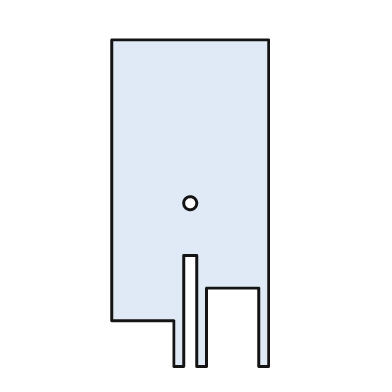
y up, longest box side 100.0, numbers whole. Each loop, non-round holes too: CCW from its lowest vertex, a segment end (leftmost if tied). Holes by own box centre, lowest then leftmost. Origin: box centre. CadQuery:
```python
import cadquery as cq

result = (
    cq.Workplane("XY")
    .moveTo(-5.0, -50.0)
    .lineTo(-2.0, -50.0)
    .lineTo(-2.0, -16.0)
    .lineTo(2.0, -16.0)
    .lineTo(2.0, -50.0)
    .lineTo(5.0, -50.0)
    .lineTo(5.0, -26.0)
    .lineTo(21.0, -26.0)
    .lineTo(21.0, -50.0)
    .lineTo(24.0, -50.0)
    .lineTo(24.0, 50.0)
    .lineTo(-24.0, 50.0)
    .lineTo(-24.0, -36.0)
    .lineTo(-5.0, -36.0)
    .close()
    .moveTo(0.0, 0.0)
    .circle(2.0)
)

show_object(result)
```